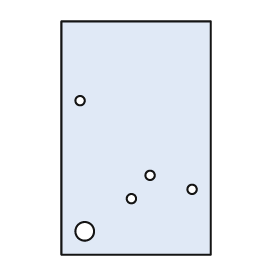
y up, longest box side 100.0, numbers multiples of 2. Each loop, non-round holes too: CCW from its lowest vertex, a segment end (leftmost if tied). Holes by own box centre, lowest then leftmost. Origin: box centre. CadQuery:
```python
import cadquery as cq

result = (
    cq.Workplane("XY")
    .moveTo(-32.0, -50.0)
    .lineTo(32.0, -50.0)
    .lineTo(32.0, 50.0)
    .lineTo(-32.0, 50.0)
    .close()
    .moveTo(-22.0, -40.0)
    .circle(4.0)
    .moveTo(-2.0, -26.0)
    .circle(2.0)
    .moveTo(24.0, -22.0)
    .circle(2.0)
    .moveTo(6.0, -16.0)
    .circle(2.0)
    .moveTo(-24.0, 16.0)
    .circle(2.0)
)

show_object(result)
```